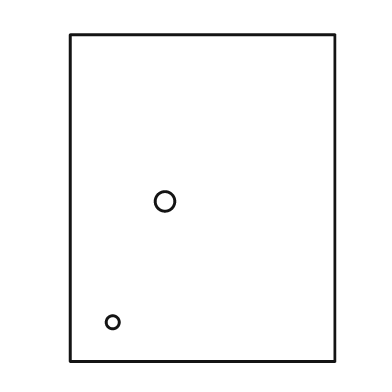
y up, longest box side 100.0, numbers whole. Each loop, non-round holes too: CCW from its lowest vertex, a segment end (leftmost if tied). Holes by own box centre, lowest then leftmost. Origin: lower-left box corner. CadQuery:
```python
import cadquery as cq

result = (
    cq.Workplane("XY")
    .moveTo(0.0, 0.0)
    .lineTo(81.0, 0.0)
    .lineTo(81.0, 100.0)
    .lineTo(0.0, 100.0)
    .close()
    .moveTo(13.0, 12.0)
    .circle(2.0)
    .moveTo(29.0, 49.0)
    .circle(3.0)
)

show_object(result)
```